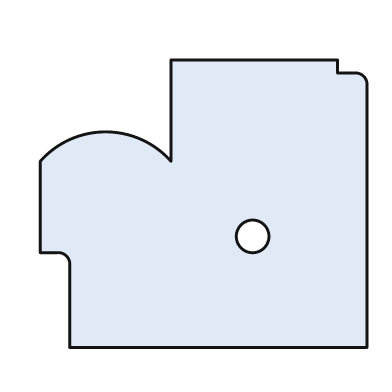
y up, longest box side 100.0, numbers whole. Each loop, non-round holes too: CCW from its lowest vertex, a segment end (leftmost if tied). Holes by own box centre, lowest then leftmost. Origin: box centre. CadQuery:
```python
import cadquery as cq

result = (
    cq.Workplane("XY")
    .moveTo(-41.0, -44.0)
    .lineTo(50.0, -44.0)
    .lineTo(50.0, 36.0)
    .threePointArc((49.0, 39.0), (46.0, 40.0))
    .lineTo(41.0, 40.0)
    .lineTo(41.0, 44.0)
    .lineTo(-10.0, 44.0)
    .lineTo(-10.0, 13.0)
    .threePointArc((-30.0, 22.0), (-50.0, 13.0))
    .lineTo(-50.0, -15.0)
    .lineTo(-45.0, -15.0)
    .threePointArc((-42.0, -16.0), (-41.0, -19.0))
    .close()
    .moveTo(15.0, -10.0)
    .circle(5.0)
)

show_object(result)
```